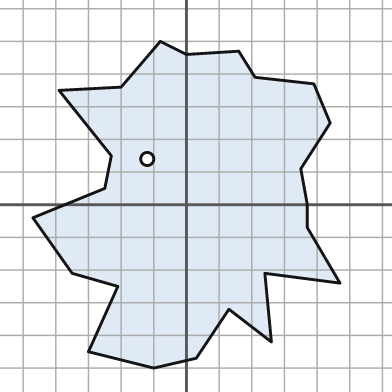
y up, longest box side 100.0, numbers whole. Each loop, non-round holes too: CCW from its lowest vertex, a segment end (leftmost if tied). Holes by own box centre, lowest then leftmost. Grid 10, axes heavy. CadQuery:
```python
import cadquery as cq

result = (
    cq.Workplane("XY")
    .moveTo(-10.0, -50.0)
    .lineTo(3.0, -47.0)
    .lineTo(13.0, -32.0)
    .lineTo(26.0, -42.0)
    .lineTo(24.0, -21.0)
    .lineTo(47.0, -24.0)
    .lineTo(37.0, -7.0)
    .lineTo(37.0, 0.0)
    .lineTo(35.0, 11.0)
    .lineTo(44.0, 25.0)
    .lineTo(39.0, 37.0)
    .lineTo(21.0, 39.0)
    .lineTo(16.0, 47.0)
    .lineTo(0.0, 46.0)
    .lineTo(-8.0, 50.0)
    .lineTo(-20.0, 36.0)
    .lineTo(-39.0, 35.0)
    .lineTo(-23.0, 15.0)
    .lineTo(-25.0, 5.0)
    .lineTo(-47.0, -4.0)
    .lineTo(-35.0, -21.0)
    .lineTo(-21.0, -25.0)
    .lineTo(-30.0, -45.0)
    .close()
    .moveTo(-12.0, 14.0)
    .circle(2.0)
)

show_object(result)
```